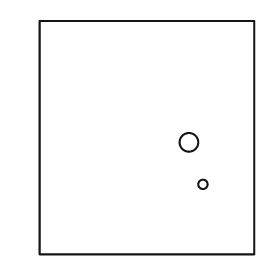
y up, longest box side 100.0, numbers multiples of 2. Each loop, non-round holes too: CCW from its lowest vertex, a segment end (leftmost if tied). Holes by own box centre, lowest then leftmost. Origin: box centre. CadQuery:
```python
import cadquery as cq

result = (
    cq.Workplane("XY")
    .moveTo(-46.0, -50.0)
    .lineTo(46.0, -50.0)
    .lineTo(46.0, 50.0)
    .lineTo(-46.0, 50.0)
    .close()
    .moveTo(24.0, -20.0)
    .circle(2.0)
    .moveTo(18.0, -2.0)
    .circle(4.0)
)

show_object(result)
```